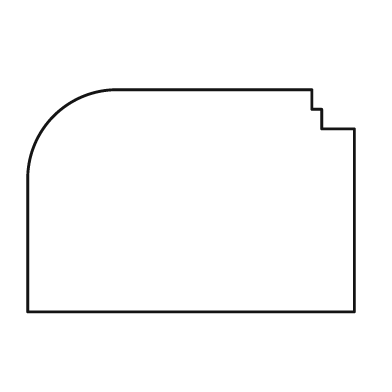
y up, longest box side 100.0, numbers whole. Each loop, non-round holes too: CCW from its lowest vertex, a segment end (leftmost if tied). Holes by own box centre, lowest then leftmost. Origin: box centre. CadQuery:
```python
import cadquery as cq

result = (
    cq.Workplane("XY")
    .moveTo(-50.0, -34.0)
    .lineTo(50.0, -34.0)
    .lineTo(50.0, 22.0)
    .lineTo(40.0, 22.0)
    .lineTo(40.0, 28.0)
    .lineTo(37.0, 28.0)
    .lineTo(37.0, 34.0)
    .lineTo(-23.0, 34.0)
    .threePointArc((-42.0, 26.0), (-50.0, 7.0))
    .close()
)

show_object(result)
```